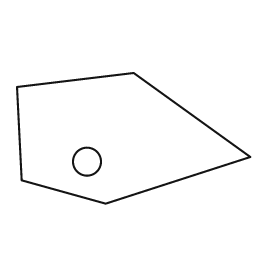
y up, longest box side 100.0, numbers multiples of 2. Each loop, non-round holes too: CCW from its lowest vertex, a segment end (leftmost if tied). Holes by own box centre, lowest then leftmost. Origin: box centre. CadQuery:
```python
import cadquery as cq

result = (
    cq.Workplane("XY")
    .moveTo(-12.0, -28.0)
    .lineTo(50.0, -8.0)
    .lineTo(0.0, 28.0)
    .lineTo(-50.0, 22.0)
    .lineTo(-48.0, -18.0)
    .close()
    .moveTo(-20.0, -10.0)
    .circle(6.0)
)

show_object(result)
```